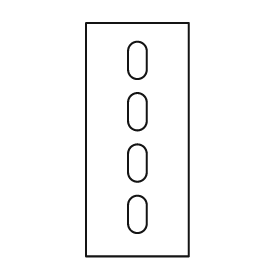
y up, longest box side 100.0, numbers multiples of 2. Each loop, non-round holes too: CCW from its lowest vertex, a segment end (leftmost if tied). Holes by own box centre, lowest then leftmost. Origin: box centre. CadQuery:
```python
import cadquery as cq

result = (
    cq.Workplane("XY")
    .moveTo(-22.0, -50.0)
    .lineTo(22.0, -50.0)
    .lineTo(22.0, 50.0)
    .lineTo(-22.0, 50.0)
    .close()
    .moveTo(-4.0, -36.0)
    .threePointArc((0.0, -40.0), (4.0, -36.0))
    .lineTo(4.0, -28.0)
    .threePointArc((0.0, -24.0), (-4.0, -28.0))
    .close()
    .moveTo(-4.0, -14.0)
    .threePointArc((0.0, -18.0), (4.0, -14.0))
    .lineTo(4.0, -6.0)
    .threePointArc((0.0, -2.0), (-4.0, -6.0))
    .close()
    .moveTo(-4.0, 8.0)
    .threePointArc((0.0, 4.0), (4.0, 8.0))
    .lineTo(4.0, 16.0)
    .threePointArc((0.0, 20.0), (-4.0, 16.0))
    .close()
    .moveTo(-4.0, 30.0)
    .threePointArc((0.0, 26.0), (4.0, 30.0))
    .lineTo(4.0, 38.0)
    .threePointArc((0.0, 42.0), (-4.0, 38.0))
    .close()
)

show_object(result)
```